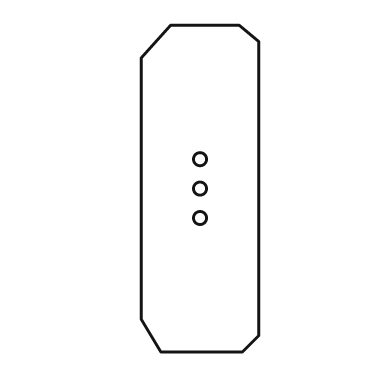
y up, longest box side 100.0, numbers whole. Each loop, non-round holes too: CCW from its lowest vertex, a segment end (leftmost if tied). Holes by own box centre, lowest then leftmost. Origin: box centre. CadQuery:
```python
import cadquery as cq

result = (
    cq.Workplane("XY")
    .moveTo(-12.0, -50.0)
    .lineTo(13.0, -50.0)
    .lineTo(18.0, -45.0)
    .lineTo(18.0, 45.0)
    .lineTo(12.0, 50.0)
    .lineTo(-9.0, 50.0)
    .lineTo(-18.0, 40.0)
    .lineTo(-18.0, -40.0)
    .close()
    .moveTo(0.0, -9.0)
    .circle(2.0)
    .moveTo(0.0, 0.0)
    .circle(2.0)
    .moveTo(0.0, 9.0)
    .circle(2.0)
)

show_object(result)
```